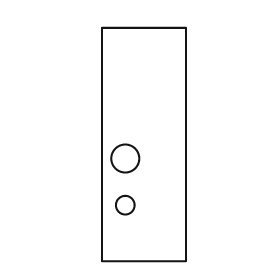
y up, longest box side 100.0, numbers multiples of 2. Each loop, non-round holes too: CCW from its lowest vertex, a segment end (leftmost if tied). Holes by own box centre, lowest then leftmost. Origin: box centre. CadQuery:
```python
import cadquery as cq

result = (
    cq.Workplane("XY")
    .moveTo(-18.0, -50.0)
    .lineTo(18.0, -50.0)
    .lineTo(18.0, 50.0)
    .lineTo(-18.0, 50.0)
    .close()
    .moveTo(-8.0, -26.0)
    .circle(4.0)
    .moveTo(-8.0, -6.0)
    .circle(6.0)
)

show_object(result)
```